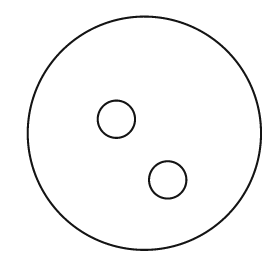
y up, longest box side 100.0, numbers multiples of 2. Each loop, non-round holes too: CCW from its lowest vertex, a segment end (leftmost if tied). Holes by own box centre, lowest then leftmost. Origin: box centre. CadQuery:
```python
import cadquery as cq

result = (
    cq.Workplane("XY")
    .moveTo(0.0, 0.0)
    .circle(50.0)
    .moveTo(10.0, -20.0)
    .circle(8.0)
    .moveTo(-12.0, 6.0)
    .circle(8.0)
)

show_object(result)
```